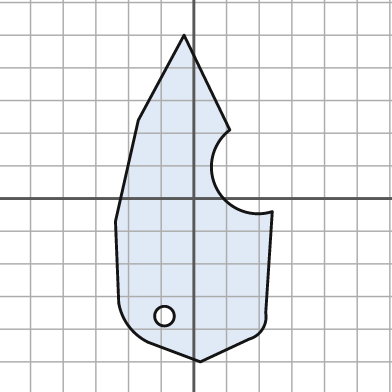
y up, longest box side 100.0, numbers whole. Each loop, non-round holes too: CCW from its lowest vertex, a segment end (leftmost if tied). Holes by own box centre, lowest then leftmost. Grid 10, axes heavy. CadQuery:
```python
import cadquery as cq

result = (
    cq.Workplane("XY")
    .moveTo(2.0, -50.0)
    .lineTo(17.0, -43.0)
    .threePointArc((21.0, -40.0), (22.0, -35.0))
    .lineTo(24.0, -4.0)
    .threePointArc((7.0, 3.0), (11.0, 21.0))
    .lineTo(-3.0, 50.0)
    .lineTo(-17.0, 24.0)
    .lineTo(-24.0, -7.0)
    .lineTo(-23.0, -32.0)
    .threePointArc((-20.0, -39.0), (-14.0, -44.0))
    .close()
    .moveTo(-9.0, -36.0)
    .circle(3.0)
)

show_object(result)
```